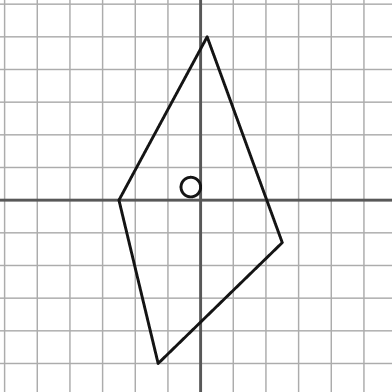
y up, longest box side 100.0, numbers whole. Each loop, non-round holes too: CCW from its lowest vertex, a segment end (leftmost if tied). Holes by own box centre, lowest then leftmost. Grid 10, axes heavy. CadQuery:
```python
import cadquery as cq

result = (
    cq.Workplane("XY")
    .moveTo(-13.0, -50.0)
    .lineTo(25.0, -13.0)
    .lineTo(2.0, 50.0)
    .lineTo(-25.0, 0.0)
    .close()
    .moveTo(-3.0, 4.0)
    .circle(3.0)
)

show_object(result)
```